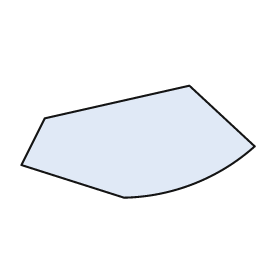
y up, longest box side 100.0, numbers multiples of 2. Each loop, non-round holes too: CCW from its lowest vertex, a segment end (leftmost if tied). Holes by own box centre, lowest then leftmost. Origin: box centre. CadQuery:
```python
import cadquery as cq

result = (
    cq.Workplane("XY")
    .moveTo(-6.0, -24.0)
    .threePointArc((24.0, -18.0), (50.0, -2.0))
    .lineTo(22.0, 24.0)
    .lineTo(-40.0, 10.0)
    .lineTo(-50.0, -10.0)
    .close()
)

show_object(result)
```